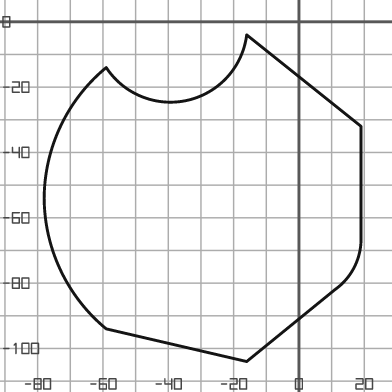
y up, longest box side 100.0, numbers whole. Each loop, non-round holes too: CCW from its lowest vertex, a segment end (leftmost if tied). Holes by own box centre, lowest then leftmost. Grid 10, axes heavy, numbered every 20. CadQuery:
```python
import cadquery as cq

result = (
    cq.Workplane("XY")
    .moveTo(-16.0, -104.0)
    .lineTo(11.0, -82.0)
    .threePointArc((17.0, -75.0), (19.0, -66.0))
    .lineTo(19.0, -32.0)
    .lineTo(-16.0, -4.0)
    .threePointArc((-34.0, -24.0), (-59.0, -14.0))
    .threePointArc((-73.0, -32.0), (-78.0, -54.0))
    .threePointArc((-73.0, -76.0), (-59.0, -94.0))
    .close()
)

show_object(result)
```